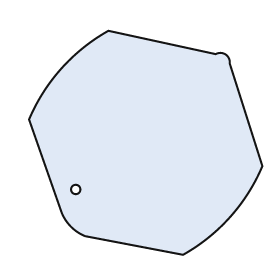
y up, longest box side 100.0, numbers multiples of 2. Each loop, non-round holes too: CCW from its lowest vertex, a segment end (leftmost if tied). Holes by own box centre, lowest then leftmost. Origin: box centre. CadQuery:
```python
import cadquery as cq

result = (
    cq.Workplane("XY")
    .moveTo(16.0, -48.0)
    .threePointArc((36.0, -32.0), (50.0, -10.0))
    .lineTo(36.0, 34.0)
    .threePointArc((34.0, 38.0), (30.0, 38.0))
    .lineTo(-16.0, 48.0)
    .threePointArc((-36.0, 32.0), (-50.0, 10.0))
    .lineTo(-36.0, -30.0)
    .threePointArc((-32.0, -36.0), (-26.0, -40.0))
    .close()
    .moveTo(-30.0, -20.0)
    .circle(2.0)
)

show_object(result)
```